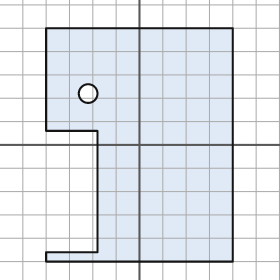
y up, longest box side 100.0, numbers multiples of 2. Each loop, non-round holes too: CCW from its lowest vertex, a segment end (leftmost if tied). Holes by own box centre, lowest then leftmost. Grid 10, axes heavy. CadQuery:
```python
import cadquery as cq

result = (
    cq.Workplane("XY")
    .moveTo(-40.0, -50.0)
    .lineTo(40.0, -50.0)
    .lineTo(40.0, 50.0)
    .lineTo(-40.0, 50.0)
    .lineTo(-40.0, 6.0)
    .lineTo(-18.0, 6.0)
    .lineTo(-18.0, -46.0)
    .lineTo(-40.0, -46.0)
    .close()
    .moveTo(-22.0, 22.0)
    .circle(4.0)
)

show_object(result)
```